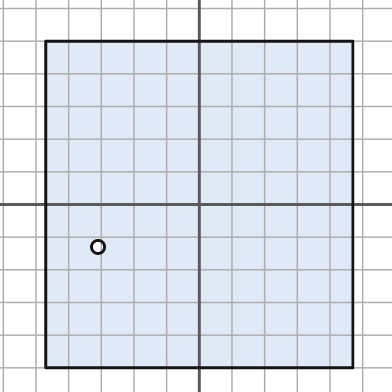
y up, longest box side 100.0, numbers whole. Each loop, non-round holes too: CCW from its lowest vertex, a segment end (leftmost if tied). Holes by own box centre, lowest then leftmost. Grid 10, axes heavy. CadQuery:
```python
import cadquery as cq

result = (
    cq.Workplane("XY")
    .moveTo(-47.0, -50.0)
    .lineTo(47.0, -50.0)
    .lineTo(47.0, 50.0)
    .lineTo(-47.0, 50.0)
    .close()
    .moveTo(-31.0, -13.0)
    .circle(2.0)
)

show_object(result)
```